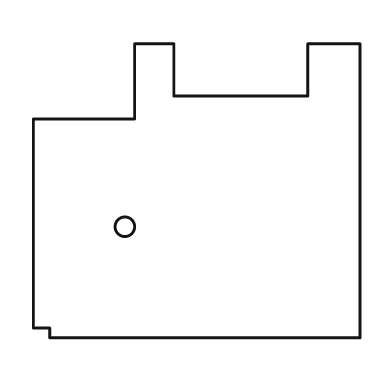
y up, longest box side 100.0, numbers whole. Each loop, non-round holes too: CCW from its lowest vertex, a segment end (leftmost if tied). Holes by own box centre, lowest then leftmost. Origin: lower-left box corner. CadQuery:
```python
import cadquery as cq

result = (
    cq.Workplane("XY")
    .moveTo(5.0, 0.0)
    .lineTo(100.0, 0.0)
    .lineTo(100.0, 90.0)
    .lineTo(84.0, 90.0)
    .lineTo(84.0, 74.0)
    .lineTo(43.0, 74.0)
    .lineTo(43.0, 90.0)
    .lineTo(31.0, 90.0)
    .lineTo(31.0, 67.0)
    .lineTo(0.0, 67.0)
    .lineTo(0.0, 3.0)
    .lineTo(5.0, 3.0)
    .close()
    .moveTo(28.0, 34.0)
    .circle(3.0)
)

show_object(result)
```